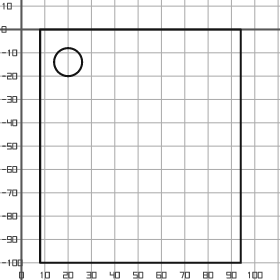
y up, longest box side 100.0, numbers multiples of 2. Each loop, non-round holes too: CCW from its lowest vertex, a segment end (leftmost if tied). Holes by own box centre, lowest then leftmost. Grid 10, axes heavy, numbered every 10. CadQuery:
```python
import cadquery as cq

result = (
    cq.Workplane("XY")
    .moveTo(8.0, -100.0)
    .lineTo(94.0, -100.0)
    .lineTo(94.0, 0.0)
    .lineTo(8.0, 0.0)
    .close()
    .moveTo(20.0, -14.0)
    .circle(6.0)
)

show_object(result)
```